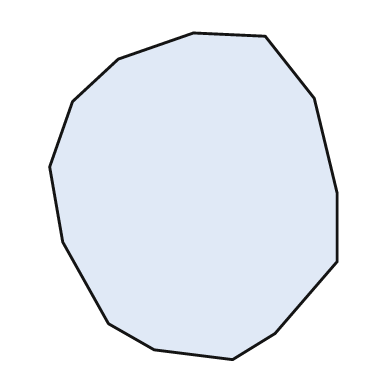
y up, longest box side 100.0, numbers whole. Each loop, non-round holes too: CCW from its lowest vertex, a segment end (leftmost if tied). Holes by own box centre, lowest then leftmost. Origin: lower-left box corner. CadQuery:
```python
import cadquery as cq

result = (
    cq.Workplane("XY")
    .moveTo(56.0, 0.0)
    .lineTo(69.0, 8.0)
    .lineTo(88.0, 30.0)
    .lineTo(88.0, 51.0)
    .lineTo(81.0, 80.0)
    .lineTo(66.0, 99.0)
    .lineTo(44.0, 100.0)
    .lineTo(21.0, 92.0)
    .lineTo(7.0, 79.0)
    .lineTo(0.0, 59.0)
    .lineTo(4.0, 36.0)
    .lineTo(18.0, 11.0)
    .lineTo(32.0, 3.0)
    .close()
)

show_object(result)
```